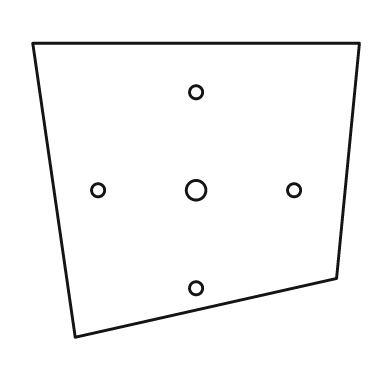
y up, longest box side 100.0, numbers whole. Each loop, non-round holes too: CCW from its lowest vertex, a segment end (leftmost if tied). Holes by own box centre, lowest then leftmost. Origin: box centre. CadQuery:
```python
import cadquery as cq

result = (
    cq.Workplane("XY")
    .moveTo(-37.0, -45.0)
    .lineTo(43.0, -27.0)
    .lineTo(50.0, 45.0)
    .lineTo(-50.0, 45.0)
    .close()
    .moveTo(0.0, -30.0)
    .circle(2.0)
    .moveTo(-30.0, 0.0)
    .circle(2.0)
    .moveTo(0.0, 0.0)
    .circle(3.0)
    .moveTo(30.0, 0.0)
    .circle(2.0)
    .moveTo(0.0, 30.0)
    .circle(2.0)
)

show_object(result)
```